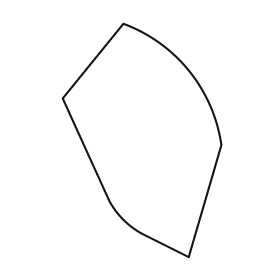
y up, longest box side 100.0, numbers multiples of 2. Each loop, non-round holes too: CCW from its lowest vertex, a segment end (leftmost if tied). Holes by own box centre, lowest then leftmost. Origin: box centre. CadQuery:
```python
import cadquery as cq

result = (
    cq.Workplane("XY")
    .moveTo(20.0, -50.0)
    .lineTo(34.0, -2.0)
    .threePointArc((20.0, 30.0), (-8.0, 50.0))
    .lineTo(-34.0, 18.0)
    .lineTo(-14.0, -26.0)
    .threePointArc((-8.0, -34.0), (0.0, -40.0))
    .close()
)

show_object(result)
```